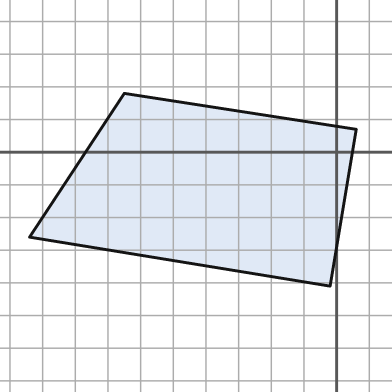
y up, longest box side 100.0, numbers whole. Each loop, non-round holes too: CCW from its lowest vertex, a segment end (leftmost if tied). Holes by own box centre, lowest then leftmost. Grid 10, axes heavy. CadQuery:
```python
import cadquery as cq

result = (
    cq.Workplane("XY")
    .moveTo(-2.0, -41.0)
    .lineTo(6.0, 7.0)
    .lineTo(-65.0, 18.0)
    .lineTo(-94.0, -26.0)
    .close()
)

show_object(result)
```